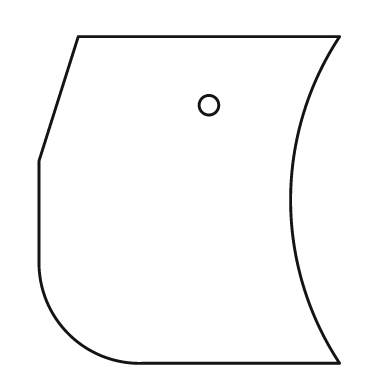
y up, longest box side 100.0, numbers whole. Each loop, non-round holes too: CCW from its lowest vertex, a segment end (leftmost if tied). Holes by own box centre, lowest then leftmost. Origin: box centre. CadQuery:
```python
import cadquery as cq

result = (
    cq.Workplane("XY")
    .moveTo(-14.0, -50.0)
    .lineTo(46.0, -50.0)
    .threePointArc((31.0, 0.0), (46.0, 50.0))
    .lineTo(-34.0, 50.0)
    .lineTo(-46.0, 12.0)
    .lineTo(-46.0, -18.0)
    .threePointArc((-37.0, -41.0), (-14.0, -50.0))
    .close()
    .moveTo(6.0, 29.0)
    .circle(3.0)
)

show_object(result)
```